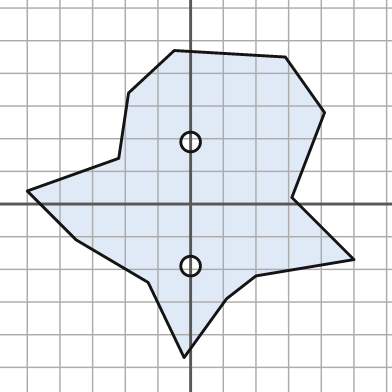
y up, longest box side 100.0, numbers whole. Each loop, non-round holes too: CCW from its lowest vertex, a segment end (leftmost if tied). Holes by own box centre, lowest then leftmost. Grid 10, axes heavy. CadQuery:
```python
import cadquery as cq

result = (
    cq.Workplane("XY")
    .moveTo(-2.0, -47.0)
    .lineTo(11.0, -29.0)
    .lineTo(20.0, -22.0)
    .lineTo(50.0, -17.0)
    .lineTo(31.0, 2.0)
    .lineTo(41.0, 28.0)
    .lineTo(29.0, 45.0)
    .lineTo(-5.0, 47.0)
    .lineTo(-19.0, 34.0)
    .lineTo(-22.0, 14.0)
    .lineTo(-50.0, 4.0)
    .lineTo(-35.0, -11.0)
    .lineTo(-13.0, -24.0)
    .close()
    .moveTo(0.0, -19.0)
    .circle(3.0)
    .moveTo(0.0, 19.0)
    .circle(3.0)
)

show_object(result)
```